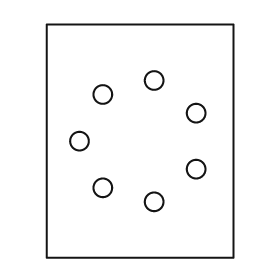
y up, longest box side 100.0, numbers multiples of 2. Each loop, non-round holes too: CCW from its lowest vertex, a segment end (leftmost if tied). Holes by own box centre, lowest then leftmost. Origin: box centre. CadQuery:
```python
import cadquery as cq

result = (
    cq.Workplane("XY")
    .moveTo(-40.0, -50.0)
    .lineTo(40.0, -50.0)
    .lineTo(40.0, 50.0)
    .lineTo(-40.0, 50.0)
    .close()
    .moveTo(6.0, -26.0)
    .circle(4.0)
    .moveTo(-16.0, -20.0)
    .circle(4.0)
    .moveTo(24.0, -12.0)
    .circle(4.0)
    .moveTo(-26.0, 0.0)
    .circle(4.0)
    .moveTo(24.0, 12.0)
    .circle(4.0)
    .moveTo(-16.0, 20.0)
    .circle(4.0)
    .moveTo(6.0, 26.0)
    .circle(4.0)
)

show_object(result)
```